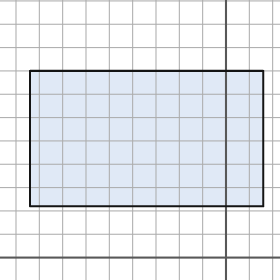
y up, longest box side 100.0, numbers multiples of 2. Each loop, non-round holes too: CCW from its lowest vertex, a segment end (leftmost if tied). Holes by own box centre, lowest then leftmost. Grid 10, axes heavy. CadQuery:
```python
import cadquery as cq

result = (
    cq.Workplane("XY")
    .moveTo(-84.0, 22.0)
    .lineTo(16.0, 22.0)
    .lineTo(16.0, 80.0)
    .lineTo(-84.0, 80.0)
    .close()
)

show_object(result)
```